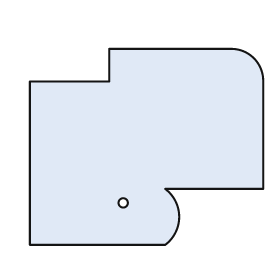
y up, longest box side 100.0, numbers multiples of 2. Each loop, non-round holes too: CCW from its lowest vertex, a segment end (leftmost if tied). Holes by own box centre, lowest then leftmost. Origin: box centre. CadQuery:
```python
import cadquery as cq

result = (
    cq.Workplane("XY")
    .moveTo(-50.0, -42.0)
    .lineTo(8.0, -42.0)
    .threePointArc((14.0, -30.0), (8.0, -18.0))
    .lineTo(50.0, -18.0)
    .lineTo(50.0, 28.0)
    .threePointArc((46.0, 38.0), (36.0, 42.0))
    .lineTo(-16.0, 42.0)
    .lineTo(-16.0, 28.0)
    .lineTo(-50.0, 28.0)
    .close()
    .moveTo(-10.0, -24.0)
    .circle(2.0)
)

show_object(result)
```